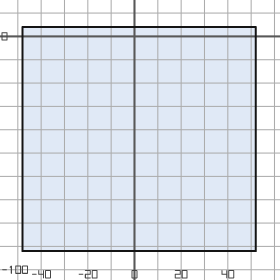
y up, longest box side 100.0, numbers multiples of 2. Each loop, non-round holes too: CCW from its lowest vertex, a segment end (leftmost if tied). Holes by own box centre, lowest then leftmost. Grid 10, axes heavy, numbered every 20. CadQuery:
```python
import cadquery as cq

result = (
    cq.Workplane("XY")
    .moveTo(-48.0, -92.0)
    .lineTo(52.0, -92.0)
    .lineTo(52.0, 4.0)
    .lineTo(-48.0, 4.0)
    .close()
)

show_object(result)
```